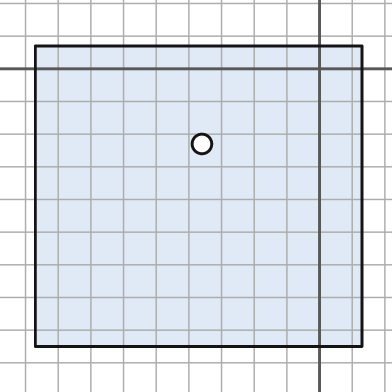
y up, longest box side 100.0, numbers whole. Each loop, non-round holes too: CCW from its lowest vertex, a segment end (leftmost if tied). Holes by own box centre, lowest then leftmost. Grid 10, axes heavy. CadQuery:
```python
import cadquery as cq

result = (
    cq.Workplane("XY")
    .moveTo(-87.0, -85.0)
    .lineTo(13.0, -85.0)
    .lineTo(13.0, 7.0)
    .lineTo(-87.0, 7.0)
    .close()
    .moveTo(-36.0, -23.0)
    .circle(3.0)
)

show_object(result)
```